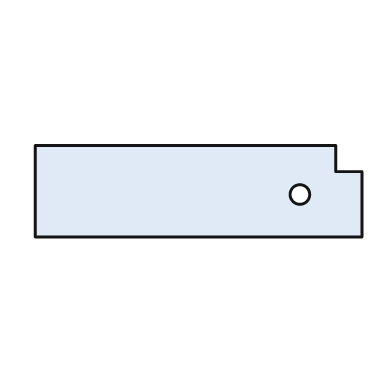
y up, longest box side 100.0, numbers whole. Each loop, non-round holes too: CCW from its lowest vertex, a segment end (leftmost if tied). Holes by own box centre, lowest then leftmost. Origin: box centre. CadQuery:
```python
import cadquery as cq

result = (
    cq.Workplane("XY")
    .moveTo(-50.0, -14.0)
    .lineTo(50.0, -14.0)
    .lineTo(50.0, 6.0)
    .lineTo(42.0, 6.0)
    .lineTo(42.0, 14.0)
    .lineTo(-50.0, 14.0)
    .close()
    .moveTo(31.0, -1.0)
    .circle(3.0)
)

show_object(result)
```